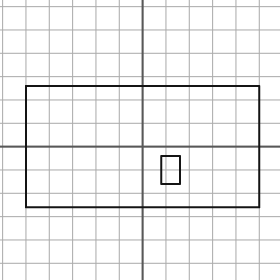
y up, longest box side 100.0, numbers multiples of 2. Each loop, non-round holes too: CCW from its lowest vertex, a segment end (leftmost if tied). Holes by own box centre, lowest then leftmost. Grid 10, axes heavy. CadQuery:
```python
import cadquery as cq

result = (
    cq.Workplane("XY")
    .moveTo(-50.0, -26.0)
    .lineTo(50.0, -26.0)
    .lineTo(50.0, 26.0)
    .lineTo(-50.0, 26.0)
    .close()
    .moveTo(8.0, -16.0)
    .lineTo(16.0, -16.0)
    .lineTo(16.0, -4.0)
    .lineTo(8.0, -4.0)
    .close()
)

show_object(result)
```